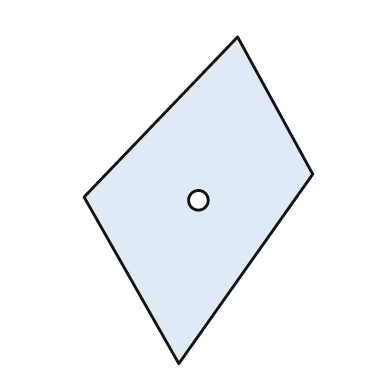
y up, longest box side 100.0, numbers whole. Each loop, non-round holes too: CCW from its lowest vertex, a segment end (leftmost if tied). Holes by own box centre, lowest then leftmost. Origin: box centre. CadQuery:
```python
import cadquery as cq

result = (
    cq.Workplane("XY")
    .moveTo(-6.0, -50.0)
    .lineTo(35.0, 8.0)
    .lineTo(12.0, 50.0)
    .lineTo(-35.0, 1.0)
    .close()
    .moveTo(0.0, 0.0)
    .circle(3.0)
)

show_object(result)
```